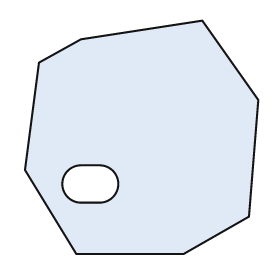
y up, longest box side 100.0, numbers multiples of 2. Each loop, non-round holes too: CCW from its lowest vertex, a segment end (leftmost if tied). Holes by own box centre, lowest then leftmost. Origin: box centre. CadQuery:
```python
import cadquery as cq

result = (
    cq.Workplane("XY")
    .moveTo(-28.0, -50.0)
    .lineTo(18.0, -50.0)
    .lineTo(46.0, -34.0)
    .lineTo(50.0, 16.0)
    .lineTo(26.0, 50.0)
    .lineTo(-26.0, 42.0)
    .lineTo(-44.0, 32.0)
    .lineTo(-50.0, -14.0)
    .close()
    .moveTo(-26.0, -28.0)
    .lineTo(-18.0, -28.0)
    .threePointArc((-10.0, -20.0), (-18.0, -12.0))
    .lineTo(-26.0, -12.0)
    .threePointArc((-34.0, -20.0), (-26.0, -28.0))
    .close()
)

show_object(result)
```